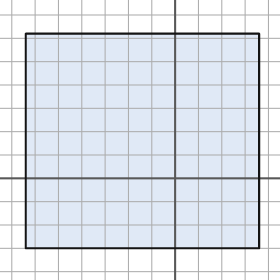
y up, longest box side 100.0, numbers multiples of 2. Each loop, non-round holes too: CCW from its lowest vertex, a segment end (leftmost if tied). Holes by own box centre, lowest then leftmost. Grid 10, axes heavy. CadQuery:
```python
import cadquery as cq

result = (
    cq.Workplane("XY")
    .moveTo(-64.0, -30.0)
    .lineTo(36.0, -30.0)
    .lineTo(36.0, 62.0)
    .lineTo(-64.0, 62.0)
    .close()
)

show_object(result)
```